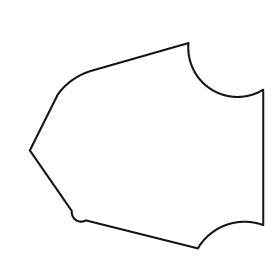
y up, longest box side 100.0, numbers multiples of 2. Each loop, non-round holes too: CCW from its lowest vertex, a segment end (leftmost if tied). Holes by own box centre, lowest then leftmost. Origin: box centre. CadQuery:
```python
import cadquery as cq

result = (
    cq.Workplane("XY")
    .moveTo(22.0, -44.0)
    .threePointArc((34.0, -34.0), (50.0, -34.0))
    .lineTo(50.0, 24.0)
    .threePointArc((28.0, 24.0), (18.0, 44.0))
    .lineTo(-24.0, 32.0)
    .threePointArc((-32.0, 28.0), (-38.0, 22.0))
    .lineTo(-50.0, -2.0)
    .lineTo(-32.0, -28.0)
    .threePointArc((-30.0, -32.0), (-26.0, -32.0))
    .close()
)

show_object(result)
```